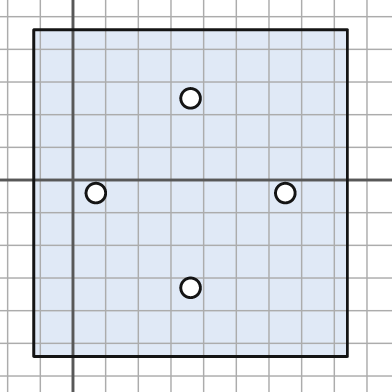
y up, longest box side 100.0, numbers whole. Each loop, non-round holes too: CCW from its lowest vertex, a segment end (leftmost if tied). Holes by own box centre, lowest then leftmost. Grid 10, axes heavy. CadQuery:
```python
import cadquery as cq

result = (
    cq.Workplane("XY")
    .moveTo(-12.0, -54.0)
    .lineTo(84.0, -54.0)
    .lineTo(84.0, 46.0)
    .lineTo(-12.0, 46.0)
    .close()
    .moveTo(36.0, -33.0)
    .circle(3.0)
    .moveTo(7.0, -4.0)
    .circle(3.0)
    .moveTo(65.0, -4.0)
    .circle(3.0)
    .moveTo(36.0, 25.0)
    .circle(3.0)
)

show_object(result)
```